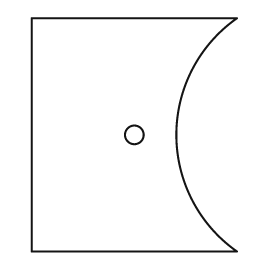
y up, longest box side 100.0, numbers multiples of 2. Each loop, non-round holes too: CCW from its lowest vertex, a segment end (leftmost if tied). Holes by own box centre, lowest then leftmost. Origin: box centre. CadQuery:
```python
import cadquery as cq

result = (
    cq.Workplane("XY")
    .moveTo(-44.0, -50.0)
    .lineTo(44.0, -50.0)
    .threePointArc((18.0, 0.0), (44.0, 50.0))
    .lineTo(-44.0, 50.0)
    .close()
    .moveTo(0.0, 0.0)
    .circle(4.0)
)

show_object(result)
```